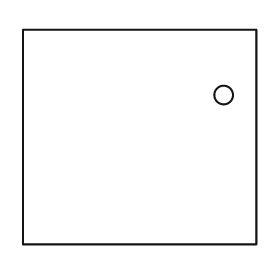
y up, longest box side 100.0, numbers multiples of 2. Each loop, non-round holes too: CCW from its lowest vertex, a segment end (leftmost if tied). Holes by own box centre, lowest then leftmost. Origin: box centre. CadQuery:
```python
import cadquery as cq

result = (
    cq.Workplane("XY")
    .moveTo(-50.0, -46.0)
    .lineTo(50.0, -46.0)
    .lineTo(50.0, 46.0)
    .lineTo(-50.0, 46.0)
    .close()
    .moveTo(36.0, 18.0)
    .circle(4.0)
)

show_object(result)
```